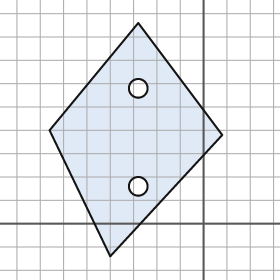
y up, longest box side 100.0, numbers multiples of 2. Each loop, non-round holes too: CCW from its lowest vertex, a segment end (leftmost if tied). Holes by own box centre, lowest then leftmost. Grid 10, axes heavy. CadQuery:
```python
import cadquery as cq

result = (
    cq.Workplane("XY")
    .moveTo(-40.0, -14.0)
    .lineTo(8.0, 38.0)
    .lineTo(-28.0, 86.0)
    .lineTo(-66.0, 40.0)
    .close()
    .moveTo(-28.0, 16.0)
    .circle(4.0)
    .moveTo(-28.0, 58.0)
    .circle(4.0)
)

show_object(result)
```